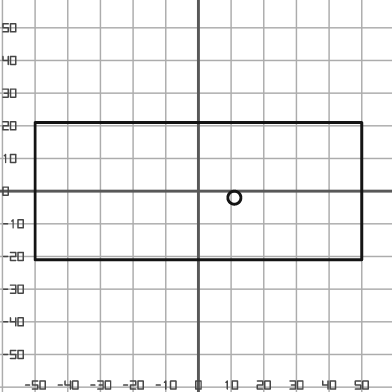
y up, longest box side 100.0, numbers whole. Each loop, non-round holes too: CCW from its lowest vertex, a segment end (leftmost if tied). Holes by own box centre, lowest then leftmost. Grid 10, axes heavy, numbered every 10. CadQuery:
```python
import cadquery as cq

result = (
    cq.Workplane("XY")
    .moveTo(-50.0, -21.0)
    .lineTo(50.0, -21.0)
    .lineTo(50.0, 21.0)
    .lineTo(-50.0, 21.0)
    .close()
    .moveTo(11.0, -2.0)
    .circle(2.0)
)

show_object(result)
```